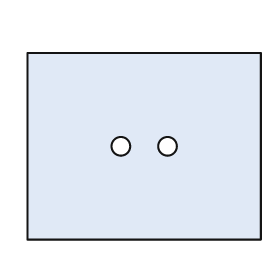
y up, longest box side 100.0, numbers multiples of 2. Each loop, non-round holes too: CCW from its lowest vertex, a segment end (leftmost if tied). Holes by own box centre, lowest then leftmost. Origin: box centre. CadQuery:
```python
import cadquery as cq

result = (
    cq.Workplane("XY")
    .moveTo(-50.0, -40.0)
    .lineTo(50.0, -40.0)
    .lineTo(50.0, 40.0)
    .lineTo(-50.0, 40.0)
    .close()
    .moveTo(-10.0, 0.0)
    .circle(4.0)
    .moveTo(10.0, 0.0)
    .circle(4.0)
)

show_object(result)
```